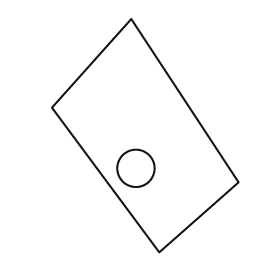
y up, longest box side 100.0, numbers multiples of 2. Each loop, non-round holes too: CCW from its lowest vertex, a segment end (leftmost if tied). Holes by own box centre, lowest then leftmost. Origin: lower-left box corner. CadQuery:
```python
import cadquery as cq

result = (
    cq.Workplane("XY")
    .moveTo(46.0, 0.0)
    .lineTo(80.0, 30.0)
    .lineTo(34.0, 100.0)
    .lineTo(0.0, 62.0)
    .close()
    .moveTo(36.0, 36.0)
    .circle(8.0)
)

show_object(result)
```